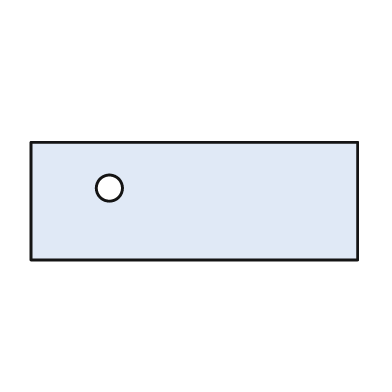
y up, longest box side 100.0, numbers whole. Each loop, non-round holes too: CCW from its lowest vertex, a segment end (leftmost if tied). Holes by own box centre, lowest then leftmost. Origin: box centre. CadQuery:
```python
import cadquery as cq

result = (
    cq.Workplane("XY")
    .moveTo(-50.0, -18.0)
    .lineTo(50.0, -18.0)
    .lineTo(50.0, 18.0)
    .lineTo(-50.0, 18.0)
    .close()
    .moveTo(-26.0, 4.0)
    .circle(4.0)
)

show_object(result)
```